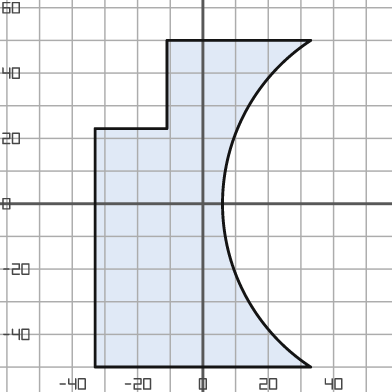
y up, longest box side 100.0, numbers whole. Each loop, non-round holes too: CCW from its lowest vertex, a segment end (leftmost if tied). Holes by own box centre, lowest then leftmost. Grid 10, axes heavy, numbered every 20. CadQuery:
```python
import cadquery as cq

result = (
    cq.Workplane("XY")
    .moveTo(-33.0, -50.0)
    .lineTo(33.0, -50.0)
    .threePointArc((6.0, 0.0), (33.0, 50.0))
    .lineTo(-11.0, 50.0)
    .lineTo(-11.0, 23.0)
    .lineTo(-33.0, 23.0)
    .close()
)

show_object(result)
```